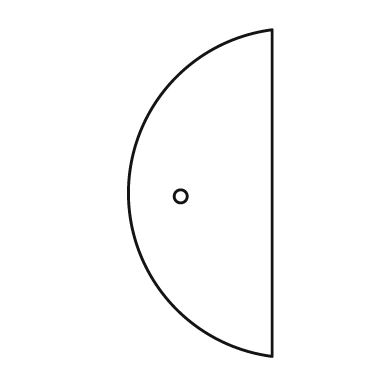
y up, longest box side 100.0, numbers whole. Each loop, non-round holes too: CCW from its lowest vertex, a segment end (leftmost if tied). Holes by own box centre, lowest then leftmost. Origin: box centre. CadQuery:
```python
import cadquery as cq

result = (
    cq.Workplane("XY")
    .moveTo(22.0, -50.0)
    .lineTo(22.0, 50.0)
    .threePointArc((-22.0, 0.0), (22.0, -50.0))
    .close()
    .moveTo(-6.0, -1.0)
    .circle(2.0)
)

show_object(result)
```